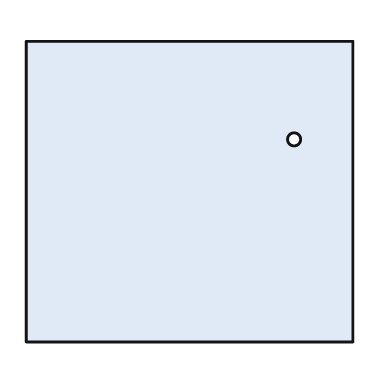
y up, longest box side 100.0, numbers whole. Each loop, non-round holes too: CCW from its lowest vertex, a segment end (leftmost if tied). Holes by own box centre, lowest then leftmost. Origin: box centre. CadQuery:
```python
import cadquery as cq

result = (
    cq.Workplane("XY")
    .moveTo(-50.0, -46.0)
    .lineTo(50.0, -46.0)
    .lineTo(50.0, 46.0)
    .lineTo(-50.0, 46.0)
    .close()
    .moveTo(32.0, 16.0)
    .circle(2.0)
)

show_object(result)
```